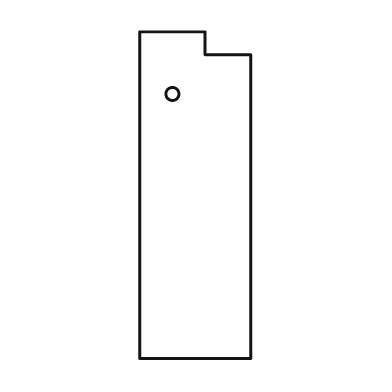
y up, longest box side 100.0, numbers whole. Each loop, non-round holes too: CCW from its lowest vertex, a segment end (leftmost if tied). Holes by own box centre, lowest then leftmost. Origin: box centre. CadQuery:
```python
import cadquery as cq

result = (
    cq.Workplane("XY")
    .moveTo(-17.0, -50.0)
    .lineTo(17.0, -50.0)
    .lineTo(17.0, 43.0)
    .lineTo(3.0, 43.0)
    .lineTo(3.0, 50.0)
    .lineTo(-17.0, 50.0)
    .close()
    .moveTo(-7.0, 31.0)
    .circle(2.0)
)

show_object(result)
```